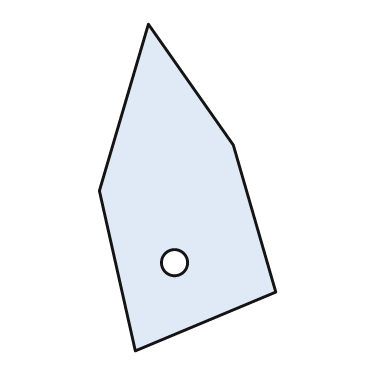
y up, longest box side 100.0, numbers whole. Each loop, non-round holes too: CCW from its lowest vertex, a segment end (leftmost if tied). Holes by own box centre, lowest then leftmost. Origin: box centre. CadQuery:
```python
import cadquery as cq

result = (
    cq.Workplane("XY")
    .moveTo(-16.0, -50.0)
    .lineTo(27.0, -32.0)
    .lineTo(14.0, 13.0)
    .lineTo(-12.0, 50.0)
    .lineTo(-27.0, -1.0)
    .close()
    .moveTo(-4.0, -23.0)
    .circle(4.0)
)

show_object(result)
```